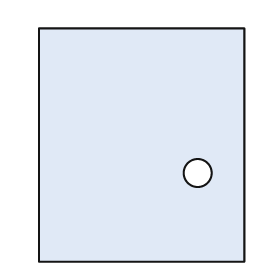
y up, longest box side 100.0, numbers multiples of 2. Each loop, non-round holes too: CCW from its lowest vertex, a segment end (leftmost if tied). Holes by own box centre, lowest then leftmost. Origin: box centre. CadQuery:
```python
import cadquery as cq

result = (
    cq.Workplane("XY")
    .moveTo(-44.0, -50.0)
    .lineTo(44.0, -50.0)
    .lineTo(44.0, 50.0)
    .lineTo(-44.0, 50.0)
    .close()
    .moveTo(24.0, -12.0)
    .circle(6.0)
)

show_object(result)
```